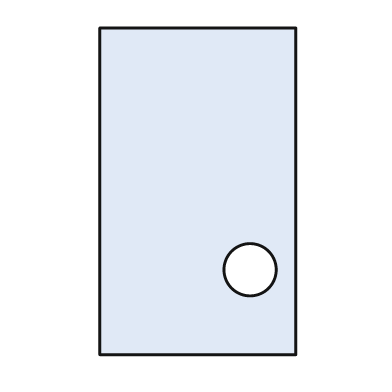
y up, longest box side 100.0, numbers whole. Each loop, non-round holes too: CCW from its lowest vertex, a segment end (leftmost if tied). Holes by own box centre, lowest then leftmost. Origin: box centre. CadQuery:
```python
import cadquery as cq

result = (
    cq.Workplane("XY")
    .moveTo(-30.0, -50.0)
    .lineTo(30.0, -50.0)
    .lineTo(30.0, 50.0)
    .lineTo(-30.0, 50.0)
    .close()
    .moveTo(16.0, -24.0)
    .circle(8.0)
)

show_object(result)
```